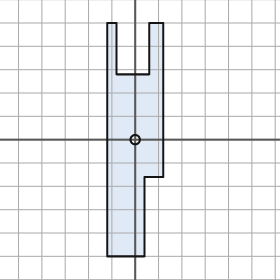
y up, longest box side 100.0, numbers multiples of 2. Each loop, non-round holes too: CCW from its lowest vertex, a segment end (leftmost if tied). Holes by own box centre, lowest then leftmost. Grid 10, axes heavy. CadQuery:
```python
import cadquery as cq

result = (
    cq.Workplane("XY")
    .moveTo(-12.0, -50.0)
    .lineTo(4.0, -50.0)
    .lineTo(4.0, -16.0)
    .lineTo(12.0, -16.0)
    .lineTo(12.0, 50.0)
    .lineTo(6.0, 50.0)
    .lineTo(6.0, 28.0)
    .lineTo(-8.0, 28.0)
    .lineTo(-8.0, 50.0)
    .lineTo(-12.0, 50.0)
    .close()
    .moveTo(0.0, 0.0)
    .circle(2.0)
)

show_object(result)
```